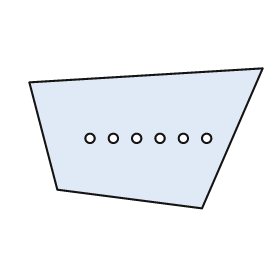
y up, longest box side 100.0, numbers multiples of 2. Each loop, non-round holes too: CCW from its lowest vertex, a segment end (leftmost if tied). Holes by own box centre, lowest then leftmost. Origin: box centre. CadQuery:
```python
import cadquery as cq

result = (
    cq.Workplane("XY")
    .moveTo(24.0, -30.0)
    .lineTo(50.0, 30.0)
    .lineTo(-50.0, 24.0)
    .lineTo(-38.0, -22.0)
    .close()
    .moveTo(-24.0, 0.0)
    .circle(2.0)
    .moveTo(-14.0, 0.0)
    .circle(2.0)
    .moveTo(-4.0, 0.0)
    .circle(2.0)
    .moveTo(6.0, 0.0)
    .circle(2.0)
    .moveTo(16.0, 0.0)
    .circle(2.0)
    .moveTo(26.0, 0.0)
    .circle(2.0)
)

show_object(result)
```